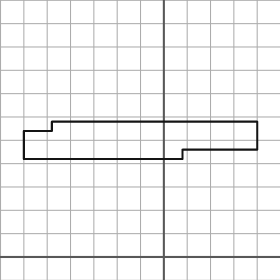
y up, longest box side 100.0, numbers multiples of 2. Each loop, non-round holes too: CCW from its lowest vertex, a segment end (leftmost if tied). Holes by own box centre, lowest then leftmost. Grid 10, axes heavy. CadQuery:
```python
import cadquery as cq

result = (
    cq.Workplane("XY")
    .moveTo(-60.0, 42.0)
    .lineTo(8.0, 42.0)
    .lineTo(8.0, 46.0)
    .lineTo(40.0, 46.0)
    .lineTo(40.0, 58.0)
    .lineTo(-48.0, 58.0)
    .lineTo(-48.0, 54.0)
    .lineTo(-60.0, 54.0)
    .close()
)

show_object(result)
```